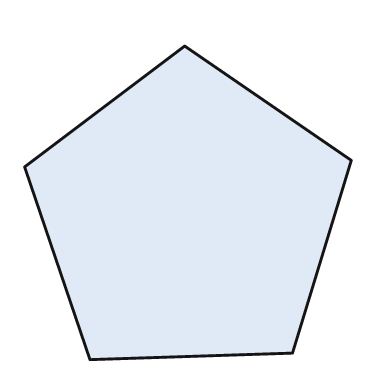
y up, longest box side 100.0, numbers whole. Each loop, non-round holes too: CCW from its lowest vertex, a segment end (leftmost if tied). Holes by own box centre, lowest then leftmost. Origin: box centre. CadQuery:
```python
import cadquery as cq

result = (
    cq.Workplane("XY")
    .moveTo(-30.0, -48.0)
    .lineTo(32.0, -46.0)
    .lineTo(50.0, 13.0)
    .lineTo(-1.0, 48.0)
    .lineTo(-50.0, 11.0)
    .close()
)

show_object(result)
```